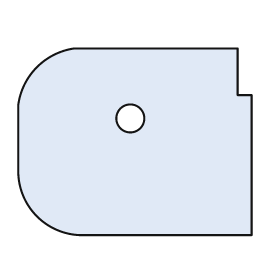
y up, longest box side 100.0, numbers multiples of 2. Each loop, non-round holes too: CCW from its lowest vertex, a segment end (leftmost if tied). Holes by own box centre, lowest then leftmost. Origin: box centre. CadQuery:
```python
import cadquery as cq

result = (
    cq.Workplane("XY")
    .moveTo(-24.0, -40.0)
    .lineTo(50.0, -40.0)
    .lineTo(50.0, 20.0)
    .lineTo(44.0, 20.0)
    .lineTo(44.0, 40.0)
    .lineTo(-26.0, 40.0)
    .threePointArc((-42.0, 32.0), (-50.0, 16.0))
    .lineTo(-50.0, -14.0)
    .threePointArc((-42.0, -32.0), (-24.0, -40.0))
    .close()
    .moveTo(-2.0, 10.0)
    .circle(6.0)
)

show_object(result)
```